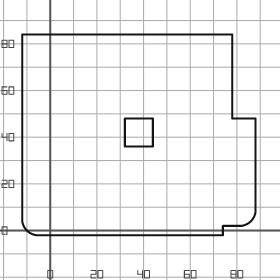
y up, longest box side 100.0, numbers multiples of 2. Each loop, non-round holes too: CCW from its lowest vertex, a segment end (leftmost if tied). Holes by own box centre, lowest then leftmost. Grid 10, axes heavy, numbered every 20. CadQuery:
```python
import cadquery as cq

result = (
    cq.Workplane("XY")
    .moveTo(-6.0, -2.0)
    .lineTo(74.0, -2.0)
    .lineTo(74.0, 2.0)
    .lineTo(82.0, 2.0)
    .threePointArc((86.0, 4.0), (88.0, 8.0))
    .lineTo(88.0, 48.0)
    .lineTo(78.0, 48.0)
    .lineTo(78.0, 84.0)
    .lineTo(-12.0, 84.0)
    .lineTo(-12.0, 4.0)
    .threePointArc((-10.0, 0.0), (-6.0, -2.0))
    .close()
    .moveTo(32.0, 36.0)
    .lineTo(44.0, 36.0)
    .lineTo(44.0, 48.0)
    .lineTo(32.0, 48.0)
    .close()
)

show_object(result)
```